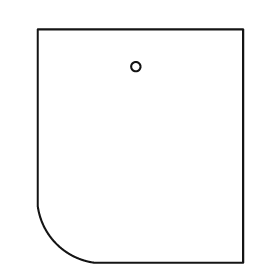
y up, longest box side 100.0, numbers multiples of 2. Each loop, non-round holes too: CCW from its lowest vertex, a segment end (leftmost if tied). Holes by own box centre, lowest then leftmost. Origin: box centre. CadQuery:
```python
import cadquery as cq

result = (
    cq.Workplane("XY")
    .moveTo(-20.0, -50.0)
    .lineTo(44.0, -50.0)
    .lineTo(44.0, 50.0)
    .lineTo(-44.0, 50.0)
    .lineTo(-44.0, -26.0)
    .threePointArc((-36.0, -42.0), (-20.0, -50.0))
    .close()
    .moveTo(-2.0, 34.0)
    .circle(2.0)
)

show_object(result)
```